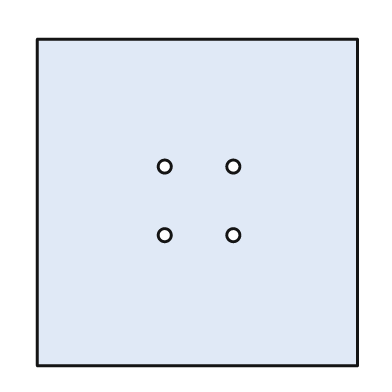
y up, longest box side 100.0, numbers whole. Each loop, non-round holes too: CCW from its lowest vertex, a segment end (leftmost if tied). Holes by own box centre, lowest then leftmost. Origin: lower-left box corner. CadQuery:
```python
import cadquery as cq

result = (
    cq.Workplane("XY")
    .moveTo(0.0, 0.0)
    .lineTo(98.0, 0.0)
    .lineTo(98.0, 100.0)
    .lineTo(0.0, 100.0)
    .close()
    .moveTo(39.0, 40.0)
    .circle(2.0)
    .moveTo(60.0, 40.0)
    .circle(2.0)
    .moveTo(39.0, 61.0)
    .circle(2.0)
    .moveTo(60.0, 61.0)
    .circle(2.0)
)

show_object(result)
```